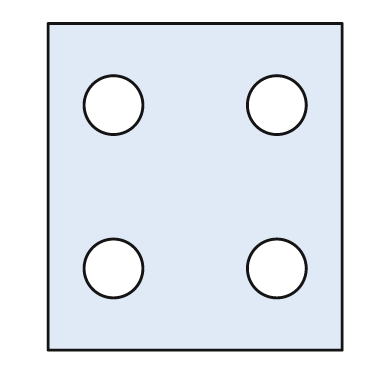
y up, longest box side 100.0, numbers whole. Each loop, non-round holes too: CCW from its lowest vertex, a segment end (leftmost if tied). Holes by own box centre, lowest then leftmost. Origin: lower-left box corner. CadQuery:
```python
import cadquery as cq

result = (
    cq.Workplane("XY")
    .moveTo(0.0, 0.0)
    .lineTo(90.0, 0.0)
    .lineTo(90.0, 100.0)
    .lineTo(0.0, 100.0)
    .close()
    .moveTo(20.0, 25.0)
    .circle(9.0)
    .moveTo(70.0, 25.0)
    .circle(9.0)
    .moveTo(20.0, 75.0)
    .circle(9.0)
    .moveTo(70.0, 75.0)
    .circle(9.0)
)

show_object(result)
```